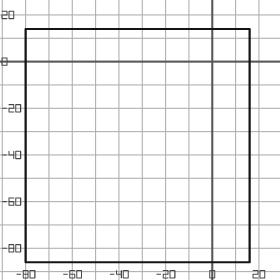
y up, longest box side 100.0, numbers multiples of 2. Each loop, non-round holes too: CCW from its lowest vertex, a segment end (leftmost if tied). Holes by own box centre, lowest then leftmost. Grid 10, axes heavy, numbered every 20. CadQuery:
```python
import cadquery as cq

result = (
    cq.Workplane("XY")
    .moveTo(-80.0, -86.0)
    .lineTo(16.0, -86.0)
    .lineTo(16.0, 14.0)
    .lineTo(-80.0, 14.0)
    .close()
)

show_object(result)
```